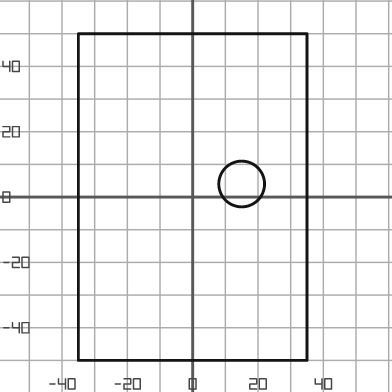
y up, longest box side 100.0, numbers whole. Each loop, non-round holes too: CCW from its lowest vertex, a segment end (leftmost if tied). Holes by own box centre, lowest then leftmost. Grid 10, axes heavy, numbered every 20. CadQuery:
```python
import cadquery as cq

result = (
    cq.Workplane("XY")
    .moveTo(-35.0, -50.0)
    .lineTo(35.0, -50.0)
    .lineTo(35.0, 50.0)
    .lineTo(-35.0, 50.0)
    .close()
    .moveTo(15.0, 4.0)
    .circle(7.0)
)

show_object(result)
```